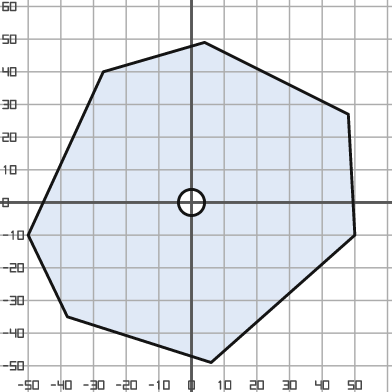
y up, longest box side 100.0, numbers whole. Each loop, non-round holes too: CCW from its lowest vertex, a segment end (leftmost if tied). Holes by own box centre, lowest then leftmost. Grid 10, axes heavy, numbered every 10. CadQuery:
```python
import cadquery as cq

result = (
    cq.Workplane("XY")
    .moveTo(6.0, -49.0)
    .lineTo(50.0, -10.0)
    .lineTo(48.0, 27.0)
    .lineTo(4.0, 49.0)
    .lineTo(-27.0, 40.0)
    .lineTo(-50.0, -10.0)
    .lineTo(-38.0, -35.0)
    .close()
    .moveTo(0.0, 0.0)
    .circle(4.0)
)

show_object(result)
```